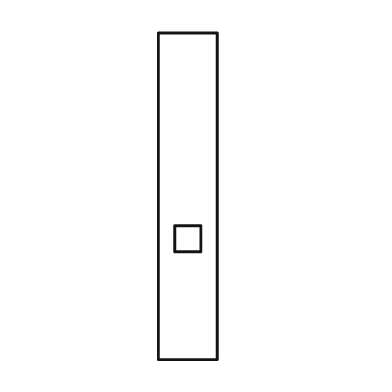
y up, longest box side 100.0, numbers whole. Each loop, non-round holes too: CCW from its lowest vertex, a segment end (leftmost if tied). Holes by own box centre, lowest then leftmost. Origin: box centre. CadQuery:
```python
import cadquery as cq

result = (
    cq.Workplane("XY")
    .moveTo(-9.0, -50.0)
    .lineTo(9.0, -50.0)
    .lineTo(9.0, 50.0)
    .lineTo(-9.0, 50.0)
    .close()
    .moveTo(-4.0, -17.0)
    .lineTo(4.0, -17.0)
    .lineTo(4.0, -9.0)
    .lineTo(-4.0, -9.0)
    .close()
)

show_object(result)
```